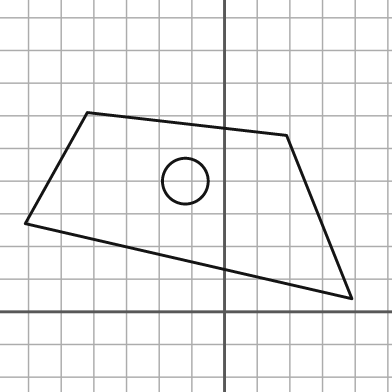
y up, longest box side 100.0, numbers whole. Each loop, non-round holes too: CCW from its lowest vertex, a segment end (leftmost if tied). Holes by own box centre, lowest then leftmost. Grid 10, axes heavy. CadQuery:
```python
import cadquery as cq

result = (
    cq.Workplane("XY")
    .moveTo(39.0, 4.0)
    .lineTo(19.0, 54.0)
    .lineTo(-42.0, 61.0)
    .lineTo(-61.0, 27.0)
    .close()
    .moveTo(-12.0, 40.0)
    .circle(7.0)
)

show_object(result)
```